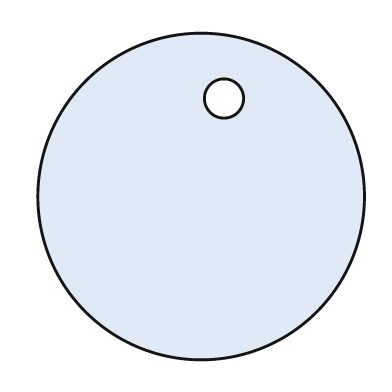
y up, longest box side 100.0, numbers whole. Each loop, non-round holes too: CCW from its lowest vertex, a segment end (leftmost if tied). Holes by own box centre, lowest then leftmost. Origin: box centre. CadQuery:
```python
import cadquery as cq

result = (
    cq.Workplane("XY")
    .moveTo(0.0, 0.0)
    .circle(50.0)
    .moveTo(7.0, 30.0)
    .circle(6.0)
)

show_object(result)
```